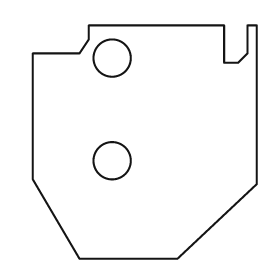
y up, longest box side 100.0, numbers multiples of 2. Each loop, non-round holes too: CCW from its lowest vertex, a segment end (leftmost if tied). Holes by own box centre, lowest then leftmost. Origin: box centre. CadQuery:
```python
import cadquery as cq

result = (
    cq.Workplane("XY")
    .moveTo(-28.0, -50.0)
    .lineTo(14.0, -50.0)
    .lineTo(48.0, -18.0)
    .lineTo(48.0, 50.0)
    .lineTo(44.0, 50.0)
    .lineTo(44.0, 38.0)
    .lineTo(40.0, 34.0)
    .lineTo(34.0, 34.0)
    .lineTo(34.0, 50.0)
    .lineTo(-24.0, 50.0)
    .lineTo(-24.0, 44.0)
    .lineTo(-28.0, 38.0)
    .lineTo(-48.0, 38.0)
    .lineTo(-48.0, -16.0)
    .close()
    .moveTo(-14.0, -8.0)
    .circle(8.0)
    .moveTo(-14.0, 36.0)
    .circle(8.0)
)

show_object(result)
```